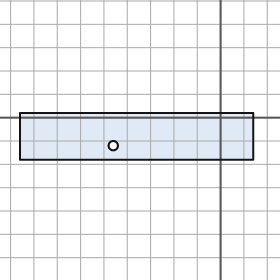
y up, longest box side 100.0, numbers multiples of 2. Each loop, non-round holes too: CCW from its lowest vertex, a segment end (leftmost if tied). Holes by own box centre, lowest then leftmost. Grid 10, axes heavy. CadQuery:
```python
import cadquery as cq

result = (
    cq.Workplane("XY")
    .moveTo(-86.0, -18.0)
    .lineTo(14.0, -18.0)
    .lineTo(14.0, 2.0)
    .lineTo(-86.0, 2.0)
    .close()
    .moveTo(-46.0, -12.0)
    .circle(2.0)
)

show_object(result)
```